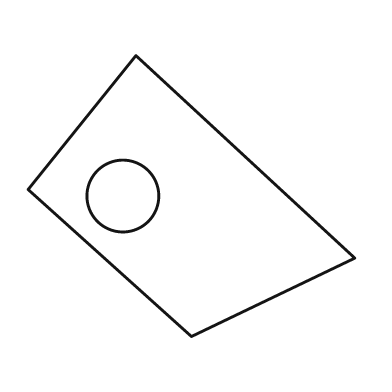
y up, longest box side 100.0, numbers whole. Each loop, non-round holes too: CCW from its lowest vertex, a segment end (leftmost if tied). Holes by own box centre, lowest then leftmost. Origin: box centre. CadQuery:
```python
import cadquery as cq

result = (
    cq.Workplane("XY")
    .moveTo(0.0, -43.0)
    .lineTo(50.0, -19.0)
    .lineTo(-17.0, 43.0)
    .lineTo(-50.0, 2.0)
    .close()
    .moveTo(-21.0, 0.0)
    .circle(11.0)
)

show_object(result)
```